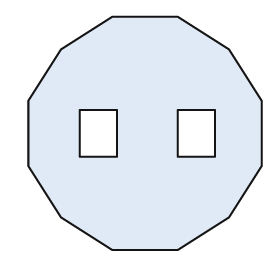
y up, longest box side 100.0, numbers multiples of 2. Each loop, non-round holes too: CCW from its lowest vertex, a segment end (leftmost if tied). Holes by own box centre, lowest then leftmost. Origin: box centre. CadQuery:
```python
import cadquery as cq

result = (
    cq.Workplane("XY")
    .moveTo(-14.0, -50.0)
    .lineTo(14.0, -50.0)
    .lineTo(36.0, -36.0)
    .lineTo(50.0, -14.0)
    .lineTo(50.0, 14.0)
    .lineTo(36.0, 36.0)
    .lineTo(14.0, 50.0)
    .lineTo(-14.0, 50.0)
    .lineTo(-36.0, 36.0)
    .lineTo(-50.0, 14.0)
    .lineTo(-50.0, -14.0)
    .lineTo(-36.0, -36.0)
    .close()
    .moveTo(-28.0, -10.0)
    .lineTo(-12.0, -10.0)
    .lineTo(-12.0, 10.0)
    .lineTo(-28.0, 10.0)
    .close()
    .moveTo(14.0, -10.0)
    .lineTo(30.0, -10.0)
    .lineTo(30.0, 10.0)
    .lineTo(14.0, 10.0)
    .close()
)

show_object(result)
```